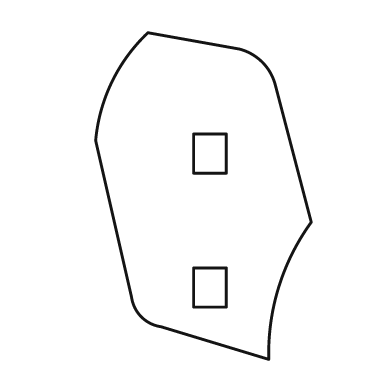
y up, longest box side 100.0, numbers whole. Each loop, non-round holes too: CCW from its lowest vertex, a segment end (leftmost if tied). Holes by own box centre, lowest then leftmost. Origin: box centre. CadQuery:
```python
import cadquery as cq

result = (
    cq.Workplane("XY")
    .moveTo(20.0, -50.0)
    .threePointArc((23.0, -28.0), (33.0, -8.0))
    .lineTo(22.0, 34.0)
    .threePointArc((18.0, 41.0), (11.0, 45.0))
    .lineTo(-17.0, 50.0)
    .threePointArc((-28.0, 35.0), (-33.0, 17.0))
    .lineTo(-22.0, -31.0)
    .threePointArc((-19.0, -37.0), (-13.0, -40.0))
    .close()
    .moveTo(-3.0, -34.0)
    .lineTo(7.0, -34.0)
    .lineTo(7.0, -22.0)
    .lineTo(-3.0, -22.0)
    .close()
    .moveTo(-3.0, 7.0)
    .lineTo(7.0, 7.0)
    .lineTo(7.0, 19.0)
    .lineTo(-3.0, 19.0)
    .close()
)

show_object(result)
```